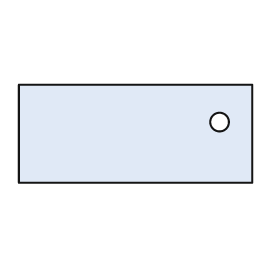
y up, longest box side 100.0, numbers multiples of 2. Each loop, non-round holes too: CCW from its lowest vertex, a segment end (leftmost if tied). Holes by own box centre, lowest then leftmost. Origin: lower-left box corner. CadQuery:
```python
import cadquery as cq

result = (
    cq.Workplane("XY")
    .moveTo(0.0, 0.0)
    .lineTo(100.0, 0.0)
    .lineTo(100.0, 42.0)
    .lineTo(0.0, 42.0)
    .close()
    .moveTo(86.0, 26.0)
    .circle(4.0)
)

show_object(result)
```